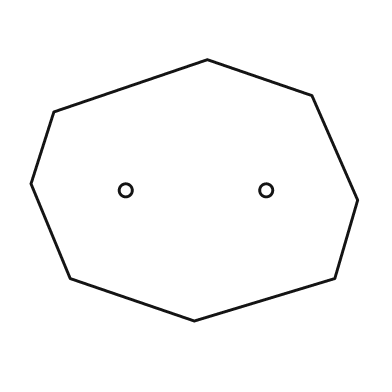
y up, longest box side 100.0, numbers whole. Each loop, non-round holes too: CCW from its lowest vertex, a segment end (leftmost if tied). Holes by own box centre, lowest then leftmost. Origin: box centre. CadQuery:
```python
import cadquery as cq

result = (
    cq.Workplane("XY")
    .moveTo(0.0, -40.0)
    .lineTo(43.0, -27.0)
    .lineTo(50.0, -3.0)
    .lineTo(36.0, 29.0)
    .lineTo(4.0, 40.0)
    .lineTo(-43.0, 24.0)
    .lineTo(-50.0, 2.0)
    .lineTo(-38.0, -27.0)
    .close()
    .moveTo(-21.0, 0.0)
    .circle(2.0)
    .moveTo(22.0, 0.0)
    .circle(2.0)
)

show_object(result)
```